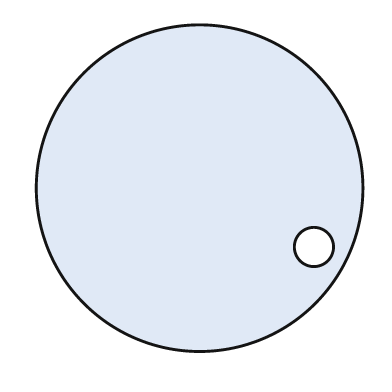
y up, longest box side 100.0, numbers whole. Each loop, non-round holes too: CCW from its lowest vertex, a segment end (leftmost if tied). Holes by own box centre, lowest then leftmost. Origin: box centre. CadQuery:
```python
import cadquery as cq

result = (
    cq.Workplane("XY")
    .moveTo(0.0, 0.0)
    .circle(50.0)
    .moveTo(35.0, -18.0)
    .circle(6.0)
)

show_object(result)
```